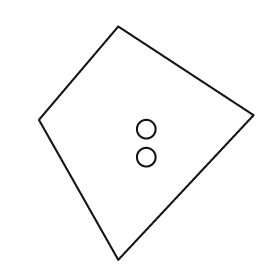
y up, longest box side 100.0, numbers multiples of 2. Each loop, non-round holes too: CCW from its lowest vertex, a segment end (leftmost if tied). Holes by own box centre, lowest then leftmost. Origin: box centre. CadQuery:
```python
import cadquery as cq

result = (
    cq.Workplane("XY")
    .moveTo(-12.0, -50.0)
    .lineTo(46.0, 12.0)
    .lineTo(-12.0, 50.0)
    .lineTo(-46.0, 10.0)
    .close()
    .moveTo(0.0, -6.0)
    .circle(4.0)
    .moveTo(0.0, 6.0)
    .circle(4.0)
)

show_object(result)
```